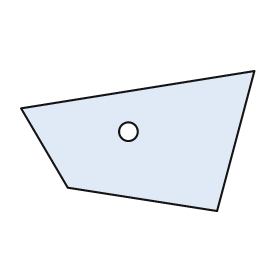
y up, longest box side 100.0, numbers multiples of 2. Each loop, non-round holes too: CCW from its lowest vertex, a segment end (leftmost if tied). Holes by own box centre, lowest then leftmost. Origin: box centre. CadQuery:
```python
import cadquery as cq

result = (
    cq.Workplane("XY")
    .moveTo(34.0, -30.0)
    .lineTo(50.0, 30.0)
    .lineTo(-50.0, 14.0)
    .lineTo(-30.0, -20.0)
    .close()
    .moveTo(-4.0, 4.0)
    .circle(4.0)
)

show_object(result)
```